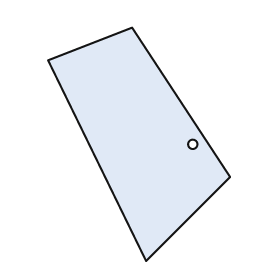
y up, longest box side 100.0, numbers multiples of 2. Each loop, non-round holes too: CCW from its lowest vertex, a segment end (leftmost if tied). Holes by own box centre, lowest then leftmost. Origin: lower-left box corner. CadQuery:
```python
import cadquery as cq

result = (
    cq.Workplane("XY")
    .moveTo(42.0, 0.0)
    .lineTo(78.0, 36.0)
    .lineTo(36.0, 100.0)
    .lineTo(0.0, 86.0)
    .close()
    .moveTo(62.0, 50.0)
    .circle(2.0)
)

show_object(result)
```